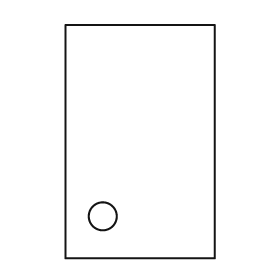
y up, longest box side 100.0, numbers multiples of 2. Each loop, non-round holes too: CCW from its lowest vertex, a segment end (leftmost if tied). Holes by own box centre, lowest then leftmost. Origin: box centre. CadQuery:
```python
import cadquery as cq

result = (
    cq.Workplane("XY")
    .moveTo(-32.0, -50.0)
    .lineTo(32.0, -50.0)
    .lineTo(32.0, 50.0)
    .lineTo(-32.0, 50.0)
    .close()
    .moveTo(-16.0, -32.0)
    .circle(6.0)
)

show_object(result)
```